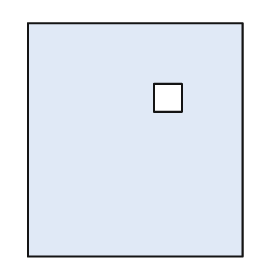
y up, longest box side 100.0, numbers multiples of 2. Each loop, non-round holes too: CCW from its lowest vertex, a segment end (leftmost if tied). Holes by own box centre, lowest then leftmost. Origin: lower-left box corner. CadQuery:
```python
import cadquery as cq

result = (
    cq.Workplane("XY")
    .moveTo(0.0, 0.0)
    .lineTo(92.0, 0.0)
    .lineTo(92.0, 100.0)
    .lineTo(0.0, 100.0)
    .close()
    .moveTo(54.0, 62.0)
    .lineTo(66.0, 62.0)
    .lineTo(66.0, 74.0)
    .lineTo(54.0, 74.0)
    .close()
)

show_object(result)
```